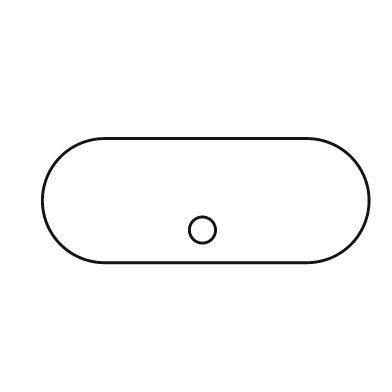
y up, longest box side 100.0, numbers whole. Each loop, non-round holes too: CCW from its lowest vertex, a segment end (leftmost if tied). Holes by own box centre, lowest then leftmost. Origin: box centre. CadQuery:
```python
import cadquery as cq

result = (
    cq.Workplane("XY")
    .moveTo(-31.0, -19.0)
    .lineTo(31.0, -19.0)
    .threePointArc((50.0, 0.0), (31.0, 19.0))
    .lineTo(-31.0, 19.0)
    .threePointArc((-50.0, 0.0), (-31.0, -19.0))
    .close()
    .moveTo(-1.0, -9.0)
    .circle(4.0)
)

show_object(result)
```